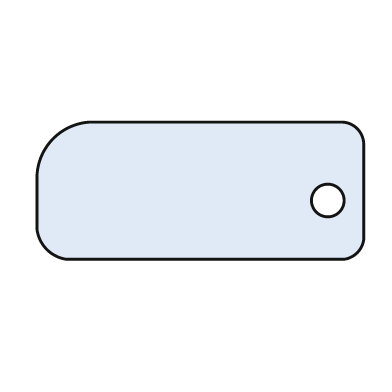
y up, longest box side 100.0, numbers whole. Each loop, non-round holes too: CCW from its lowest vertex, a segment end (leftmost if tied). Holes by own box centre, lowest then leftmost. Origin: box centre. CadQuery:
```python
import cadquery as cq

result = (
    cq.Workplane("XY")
    .moveTo(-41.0, -21.0)
    .lineTo(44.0, -21.0)
    .threePointArc((48.0, -19.0), (50.0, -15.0))
    .lineTo(50.0, 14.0)
    .threePointArc((48.0, 19.0), (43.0, 21.0))
    .lineTo(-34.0, 21.0)
    .threePointArc((-45.0, 16.0), (-50.0, 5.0))
    .lineTo(-50.0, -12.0)
    .threePointArc((-47.0, -18.0), (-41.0, -21.0))
    .close()
    .moveTo(39.0, -3.0)
    .circle(5.0)
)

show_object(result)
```